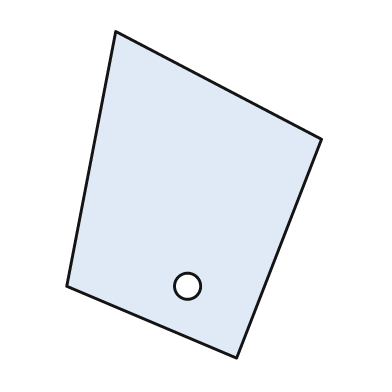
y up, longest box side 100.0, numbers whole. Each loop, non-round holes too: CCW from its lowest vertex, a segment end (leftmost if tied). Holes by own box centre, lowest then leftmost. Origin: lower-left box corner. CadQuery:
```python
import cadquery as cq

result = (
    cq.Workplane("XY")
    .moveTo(52.0, 0.0)
    .lineTo(78.0, 67.0)
    .lineTo(15.0, 100.0)
    .lineTo(0.0, 22.0)
    .close()
    .moveTo(37.0, 22.0)
    .circle(4.0)
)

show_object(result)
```